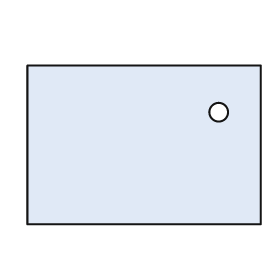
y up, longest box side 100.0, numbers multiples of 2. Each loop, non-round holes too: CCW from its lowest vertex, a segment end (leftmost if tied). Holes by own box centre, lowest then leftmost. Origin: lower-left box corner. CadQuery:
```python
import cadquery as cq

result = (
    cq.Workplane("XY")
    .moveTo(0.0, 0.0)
    .lineTo(100.0, 0.0)
    .lineTo(100.0, 68.0)
    .lineTo(0.0, 68.0)
    .close()
    .moveTo(82.0, 48.0)
    .circle(4.0)
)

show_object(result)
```